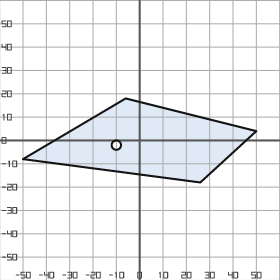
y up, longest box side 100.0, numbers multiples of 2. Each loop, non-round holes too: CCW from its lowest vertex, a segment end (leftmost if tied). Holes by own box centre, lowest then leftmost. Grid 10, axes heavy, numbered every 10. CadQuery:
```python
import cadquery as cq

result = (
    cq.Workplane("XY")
    .moveTo(26.0, -18.0)
    .lineTo(50.0, 4.0)
    .lineTo(-6.0, 18.0)
    .lineTo(-50.0, -8.0)
    .close()
    .moveTo(-10.0, -2.0)
    .circle(2.0)
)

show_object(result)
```